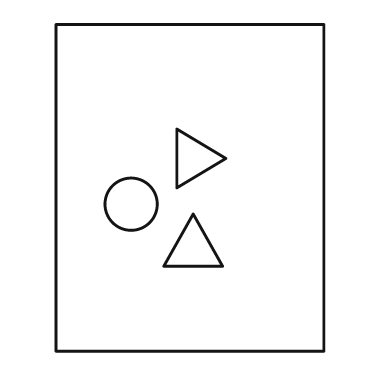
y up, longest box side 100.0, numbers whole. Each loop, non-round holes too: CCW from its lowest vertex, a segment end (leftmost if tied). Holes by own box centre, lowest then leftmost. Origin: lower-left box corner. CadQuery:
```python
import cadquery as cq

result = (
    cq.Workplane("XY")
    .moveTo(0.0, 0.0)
    .lineTo(82.0, 0.0)
    .lineTo(82.0, 100.0)
    .lineTo(0.0, 100.0)
    .close()
    .moveTo(33.0, 26.0)
    .lineTo(51.0, 26.0)
    .lineTo(42.0, 42.0)
    .close()
    .moveTo(23.0, 45.0)
    .circle(8.0)
    .moveTo(37.0, 50.0)
    .lineTo(52.0, 59.0)
    .lineTo(37.0, 68.0)
    .close()
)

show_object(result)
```